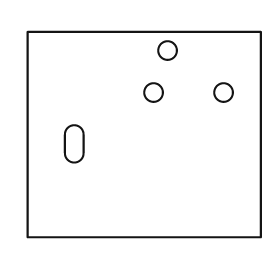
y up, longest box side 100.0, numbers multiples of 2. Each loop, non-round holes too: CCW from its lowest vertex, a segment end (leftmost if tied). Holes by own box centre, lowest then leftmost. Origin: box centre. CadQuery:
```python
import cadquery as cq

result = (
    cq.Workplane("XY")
    .moveTo(-50.0, -44.0)
    .lineTo(50.0, -44.0)
    .lineTo(50.0, 44.0)
    .lineTo(-50.0, 44.0)
    .close()
    .moveTo(-34.0, -8.0)
    .threePointArc((-30.0, -12.0), (-26.0, -8.0))
    .lineTo(-26.0, 0.0)
    .threePointArc((-30.0, 4.0), (-34.0, 0.0))
    .close()
    .moveTo(4.0, 18.0)
    .circle(4.0)
    .moveTo(34.0, 18.0)
    .circle(4.0)
    .moveTo(10.0, 36.0)
    .circle(4.0)
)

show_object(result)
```